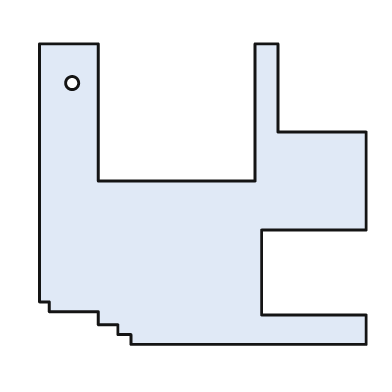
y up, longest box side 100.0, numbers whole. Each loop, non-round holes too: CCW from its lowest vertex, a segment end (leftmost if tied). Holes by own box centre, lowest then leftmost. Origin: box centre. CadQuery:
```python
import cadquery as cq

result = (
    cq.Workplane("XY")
    .moveTo(-22.0, -46.0)
    .lineTo(50.0, -46.0)
    .lineTo(50.0, -37.0)
    .lineTo(18.0, -37.0)
    .lineTo(18.0, -11.0)
    .lineTo(50.0, -11.0)
    .lineTo(50.0, 19.0)
    .lineTo(23.0, 19.0)
    .lineTo(23.0, 46.0)
    .lineTo(16.0, 46.0)
    .lineTo(16.0, 4.0)
    .lineTo(-32.0, 4.0)
    .lineTo(-32.0, 46.0)
    .lineTo(-50.0, 46.0)
    .lineTo(-50.0, -33.0)
    .lineTo(-47.0, -33.0)
    .lineTo(-47.0, -36.0)
    .lineTo(-32.0, -36.0)
    .lineTo(-32.0, -40.0)
    .lineTo(-26.0, -40.0)
    .lineTo(-26.0, -43.0)
    .lineTo(-22.0, -43.0)
    .close()
    .moveTo(-40.0, 34.0)
    .circle(2.0)
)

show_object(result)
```